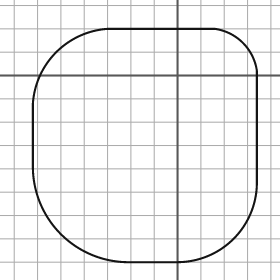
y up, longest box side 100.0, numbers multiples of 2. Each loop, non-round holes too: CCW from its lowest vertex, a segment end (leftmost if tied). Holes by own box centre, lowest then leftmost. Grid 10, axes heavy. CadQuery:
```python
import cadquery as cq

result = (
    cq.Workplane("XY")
    .moveTo(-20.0, -80.0)
    .lineTo(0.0, -80.0)
    .threePointArc((24.0, -70.0), (34.0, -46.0))
    .lineTo(34.0, 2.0)
    .threePointArc((28.0, 14.0), (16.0, 20.0))
    .lineTo(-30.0, 20.0)
    .threePointArc((-52.0, 10.0), (-62.0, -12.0))
    .lineTo(-62.0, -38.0)
    .threePointArc((-50.0, -68.0), (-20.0, -80.0))
    .close()
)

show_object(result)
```